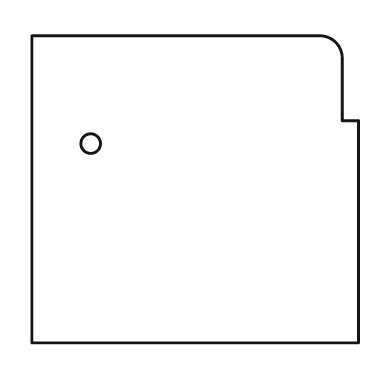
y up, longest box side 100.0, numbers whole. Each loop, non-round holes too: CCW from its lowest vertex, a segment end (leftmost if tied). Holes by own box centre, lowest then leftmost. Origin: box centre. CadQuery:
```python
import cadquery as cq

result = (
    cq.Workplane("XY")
    .moveTo(-50.0, -47.0)
    .lineTo(50.0, -47.0)
    .lineTo(50.0, 21.0)
    .lineTo(45.0, 21.0)
    .lineTo(45.0, 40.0)
    .threePointArc((43.0, 45.0), (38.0, 47.0))
    .lineTo(-50.0, 47.0)
    .close()
    .moveTo(-32.0, 14.0)
    .circle(3.0)
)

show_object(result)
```